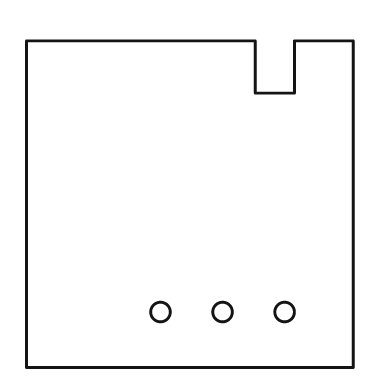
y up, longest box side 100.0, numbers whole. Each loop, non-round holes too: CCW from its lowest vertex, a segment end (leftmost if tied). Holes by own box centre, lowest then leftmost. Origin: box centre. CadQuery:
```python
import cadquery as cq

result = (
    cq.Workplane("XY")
    .moveTo(-50.0, -50.0)
    .lineTo(50.0, -50.0)
    .lineTo(50.0, 50.0)
    .lineTo(32.0, 50.0)
    .lineTo(32.0, 34.0)
    .lineTo(20.0, 34.0)
    .lineTo(20.0, 50.0)
    .lineTo(-50.0, 50.0)
    .close()
    .moveTo(-9.0, -33.0)
    .circle(3.0)
    .moveTo(10.0, -33.0)
    .circle(3.0)
    .moveTo(29.0, -33.0)
    .circle(3.0)
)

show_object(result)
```